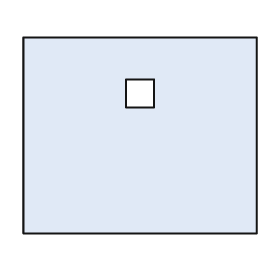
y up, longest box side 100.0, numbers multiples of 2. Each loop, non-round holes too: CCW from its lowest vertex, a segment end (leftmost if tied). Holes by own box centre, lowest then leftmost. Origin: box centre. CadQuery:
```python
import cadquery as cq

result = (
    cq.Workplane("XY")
    .moveTo(-50.0, -42.0)
    .lineTo(50.0, -42.0)
    .lineTo(50.0, 42.0)
    .lineTo(-50.0, 42.0)
    .close()
    .moveTo(-6.0, 12.0)
    .lineTo(6.0, 12.0)
    .lineTo(6.0, 24.0)
    .lineTo(-6.0, 24.0)
    .close()
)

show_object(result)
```